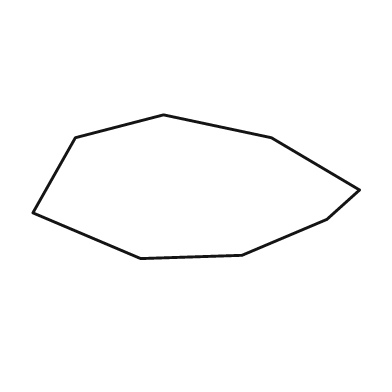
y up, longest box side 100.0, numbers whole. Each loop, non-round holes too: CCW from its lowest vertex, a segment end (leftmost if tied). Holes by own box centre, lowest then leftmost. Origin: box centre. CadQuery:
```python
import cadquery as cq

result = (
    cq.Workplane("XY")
    .moveTo(-17.0, -22.0)
    .lineTo(14.0, -21.0)
    .lineTo(40.0, -10.0)
    .lineTo(50.0, -1.0)
    .lineTo(23.0, 15.0)
    .lineTo(-10.0, 22.0)
    .lineTo(-37.0, 15.0)
    .lineTo(-50.0, -8.0)
    .close()
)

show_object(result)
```